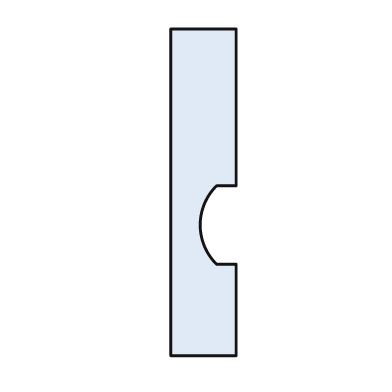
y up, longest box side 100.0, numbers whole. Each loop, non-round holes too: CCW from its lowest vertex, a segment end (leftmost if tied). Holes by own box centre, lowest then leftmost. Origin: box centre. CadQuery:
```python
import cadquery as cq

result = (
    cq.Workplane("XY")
    .moveTo(-10.0, -50.0)
    .lineTo(10.0, -50.0)
    .lineTo(10.0, -22.0)
    .lineTo(4.0, -22.0)
    .threePointArc((-1.0, -10.0), (4.0, 2.0))
    .lineTo(10.0, 2.0)
    .lineTo(10.0, 50.0)
    .lineTo(-10.0, 50.0)
    .close()
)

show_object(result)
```